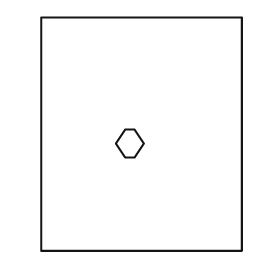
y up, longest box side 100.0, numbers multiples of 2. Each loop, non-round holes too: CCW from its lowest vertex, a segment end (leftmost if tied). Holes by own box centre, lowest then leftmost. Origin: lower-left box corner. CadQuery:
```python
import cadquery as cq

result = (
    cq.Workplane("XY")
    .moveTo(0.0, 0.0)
    .lineTo(86.0, 0.0)
    .lineTo(86.0, 100.0)
    .lineTo(0.0, 100.0)
    .close()
    .moveTo(36.0, 40.0)
    .lineTo(40.0, 40.0)
    .lineTo(44.0, 46.0)
    .lineTo(40.0, 52.0)
    .lineTo(36.0, 52.0)
    .lineTo(32.0, 46.0)
    .close()
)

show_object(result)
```